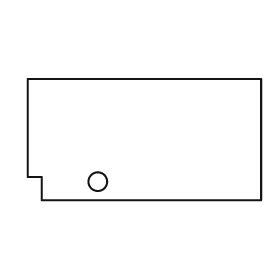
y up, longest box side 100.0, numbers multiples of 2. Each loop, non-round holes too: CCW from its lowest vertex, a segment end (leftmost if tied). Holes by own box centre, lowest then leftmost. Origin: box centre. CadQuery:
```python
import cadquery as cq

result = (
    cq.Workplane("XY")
    .moveTo(-44.0, -26.0)
    .lineTo(50.0, -26.0)
    .lineTo(50.0, 26.0)
    .lineTo(-50.0, 26.0)
    .lineTo(-50.0, -16.0)
    .lineTo(-44.0, -16.0)
    .close()
    .moveTo(-20.0, -18.0)
    .circle(4.0)
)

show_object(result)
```